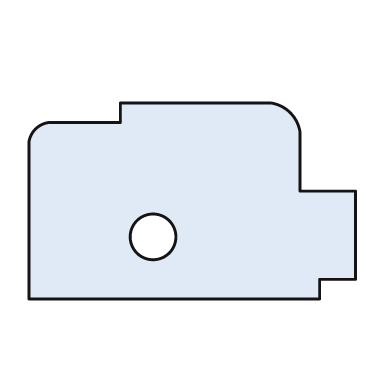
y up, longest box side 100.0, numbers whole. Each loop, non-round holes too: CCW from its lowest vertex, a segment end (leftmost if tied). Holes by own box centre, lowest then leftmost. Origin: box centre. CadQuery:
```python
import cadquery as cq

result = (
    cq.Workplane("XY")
    .moveTo(-50.0, -30.0)
    .lineTo(39.0, -30.0)
    .lineTo(39.0, -24.0)
    .lineTo(50.0, -24.0)
    .lineTo(50.0, 3.0)
    .lineTo(33.0, 3.0)
    .lineTo(33.0, 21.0)
    .threePointArc((30.0, 27.0), (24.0, 30.0))
    .lineTo(-22.0, 30.0)
    .lineTo(-22.0, 24.0)
    .lineTo(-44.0, 24.0)
    .threePointArc((-48.0, 22.0), (-50.0, 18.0))
    .close()
    .moveTo(-12.0, -11.0)
    .circle(7.0)
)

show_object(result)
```